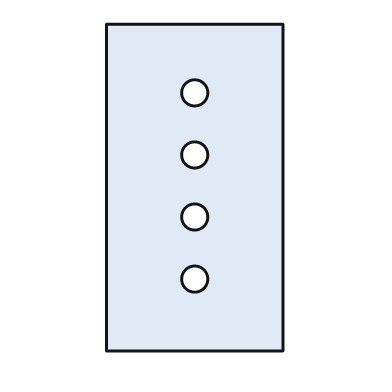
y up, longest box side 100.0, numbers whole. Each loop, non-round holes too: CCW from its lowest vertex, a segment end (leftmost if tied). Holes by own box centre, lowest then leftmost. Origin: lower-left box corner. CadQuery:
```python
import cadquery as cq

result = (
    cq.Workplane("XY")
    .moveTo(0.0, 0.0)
    .lineTo(54.0, 0.0)
    .lineTo(54.0, 100.0)
    .lineTo(0.0, 100.0)
    .close()
    .moveTo(27.0, 22.0)
    .circle(4.0)
    .moveTo(27.0, 41.0)
    .circle(4.0)
    .moveTo(27.0, 60.0)
    .circle(4.0)
    .moveTo(27.0, 79.0)
    .circle(4.0)
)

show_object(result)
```